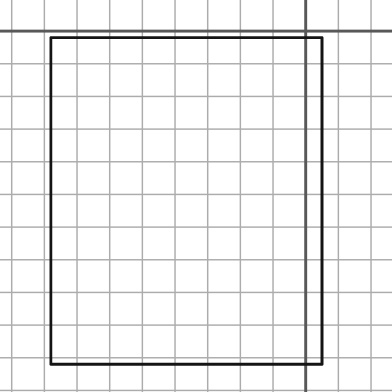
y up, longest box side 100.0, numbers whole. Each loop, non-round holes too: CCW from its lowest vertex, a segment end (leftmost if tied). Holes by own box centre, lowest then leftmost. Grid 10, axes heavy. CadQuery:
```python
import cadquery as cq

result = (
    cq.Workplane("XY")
    .moveTo(-78.0, -102.0)
    .lineTo(5.0, -102.0)
    .lineTo(5.0, -2.0)
    .lineTo(-78.0, -2.0)
    .close()
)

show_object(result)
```